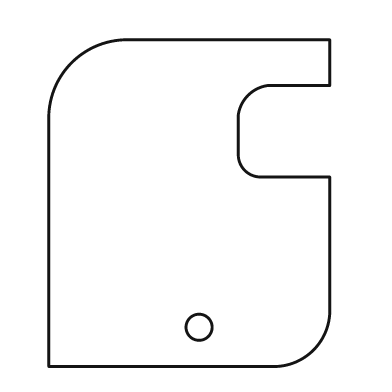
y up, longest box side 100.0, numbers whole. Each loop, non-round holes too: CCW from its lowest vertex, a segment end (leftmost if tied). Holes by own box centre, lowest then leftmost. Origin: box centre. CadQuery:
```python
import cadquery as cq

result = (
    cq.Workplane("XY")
    .moveTo(-43.0, -50.0)
    .lineTo(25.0, -50.0)
    .threePointArc((38.0, -45.0), (43.0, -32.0))
    .lineTo(43.0, 8.0)
    .lineTo(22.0, 8.0)
    .threePointArc((17.0, 10.0), (15.0, 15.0))
    .lineTo(15.0, 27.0)
    .threePointArc((18.0, 33.0), (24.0, 36.0))
    .lineTo(43.0, 36.0)
    .lineTo(43.0, 50.0)
    .lineTo(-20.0, 50.0)
    .threePointArc((-36.0, 43.0), (-43.0, 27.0))
    .close()
    .moveTo(3.0, -38.0)
    .circle(4.0)
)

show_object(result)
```